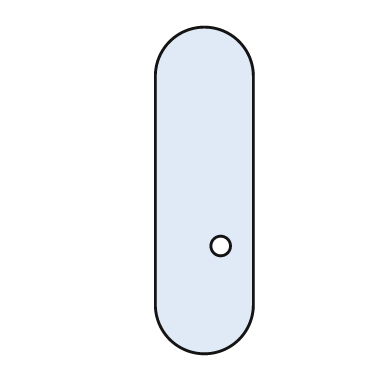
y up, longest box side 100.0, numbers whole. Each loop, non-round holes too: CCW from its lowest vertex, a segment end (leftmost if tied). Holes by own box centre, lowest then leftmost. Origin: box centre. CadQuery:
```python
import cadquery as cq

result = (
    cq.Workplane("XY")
    .moveTo(-15.0, -35.0)
    .threePointArc((0.0, -50.0), (15.0, -35.0))
    .lineTo(15.0, 35.0)
    .threePointArc((0.0, 50.0), (-15.0, 35.0))
    .close()
    .moveTo(5.0, -17.0)
    .circle(3.0)
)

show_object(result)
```